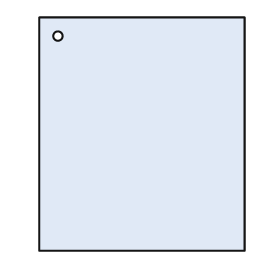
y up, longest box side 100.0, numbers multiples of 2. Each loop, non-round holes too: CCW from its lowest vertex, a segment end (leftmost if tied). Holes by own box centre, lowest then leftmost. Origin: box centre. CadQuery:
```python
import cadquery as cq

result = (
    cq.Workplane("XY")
    .moveTo(-44.0, -50.0)
    .lineTo(44.0, -50.0)
    .lineTo(44.0, 50.0)
    .lineTo(-44.0, 50.0)
    .close()
    .moveTo(-36.0, 42.0)
    .circle(2.0)
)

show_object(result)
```